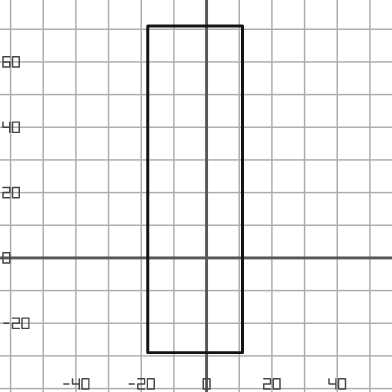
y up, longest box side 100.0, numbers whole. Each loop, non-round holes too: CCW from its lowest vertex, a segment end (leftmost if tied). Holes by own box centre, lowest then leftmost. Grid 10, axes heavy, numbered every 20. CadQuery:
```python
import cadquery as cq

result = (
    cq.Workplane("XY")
    .moveTo(-18.0, -29.0)
    .lineTo(11.0, -29.0)
    .lineTo(11.0, 71.0)
    .lineTo(-18.0, 71.0)
    .close()
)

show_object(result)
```